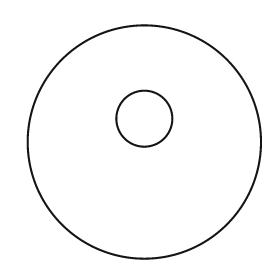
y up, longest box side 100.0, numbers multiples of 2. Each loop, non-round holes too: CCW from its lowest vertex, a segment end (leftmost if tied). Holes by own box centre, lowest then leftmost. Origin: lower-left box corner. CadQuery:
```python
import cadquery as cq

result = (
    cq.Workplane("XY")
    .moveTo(50.0, 50.0)
    .circle(50.0)
    .moveTo(50.0, 60.0)
    .circle(12.0)
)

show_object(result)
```